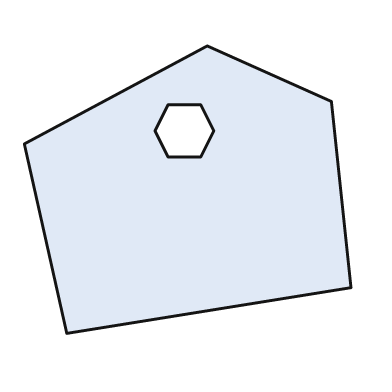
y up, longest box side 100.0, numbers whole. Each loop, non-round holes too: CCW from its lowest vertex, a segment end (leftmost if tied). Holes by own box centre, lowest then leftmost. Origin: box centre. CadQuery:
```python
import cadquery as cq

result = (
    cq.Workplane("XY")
    .moveTo(-37.0, -44.0)
    .lineTo(50.0, -30.0)
    .lineTo(44.0, 27.0)
    .lineTo(6.0, 44.0)
    .lineTo(-50.0, 14.0)
    .close()
    .moveTo(-6.0, 10.0)
    .lineTo(4.0, 10.0)
    .lineTo(8.0, 18.0)
    .lineTo(4.0, 26.0)
    .lineTo(-6.0, 26.0)
    .lineTo(-10.0, 18.0)
    .close()
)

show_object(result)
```